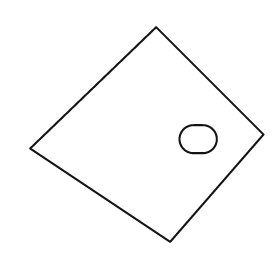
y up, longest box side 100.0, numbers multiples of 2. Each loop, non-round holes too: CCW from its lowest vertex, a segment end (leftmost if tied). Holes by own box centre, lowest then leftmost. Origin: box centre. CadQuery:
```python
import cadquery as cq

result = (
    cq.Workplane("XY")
    .moveTo(10.0, -46.0)
    .lineTo(50.0, 0.0)
    .lineTo(4.0, 46.0)
    .lineTo(-50.0, -6.0)
    .close()
    .moveTo(20.0, -8.0)
    .lineTo(24.0, -8.0)
    .threePointArc((30.0, -2.0), (24.0, 4.0))
    .lineTo(20.0, 4.0)
    .threePointArc((14.0, -2.0), (20.0, -8.0))
    .close()
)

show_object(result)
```